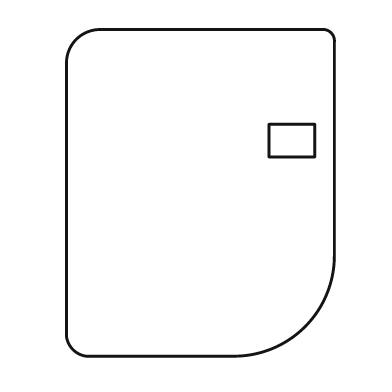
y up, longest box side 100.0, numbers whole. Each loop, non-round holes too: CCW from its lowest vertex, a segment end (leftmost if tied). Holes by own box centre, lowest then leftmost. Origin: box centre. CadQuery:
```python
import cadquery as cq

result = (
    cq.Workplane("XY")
    .moveTo(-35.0, -50.0)
    .lineTo(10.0, -50.0)
    .threePointArc((32.0, -41.0), (41.0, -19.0))
    .lineTo(41.0, 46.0)
    .threePointArc((40.0, 49.0), (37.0, 50.0))
    .lineTo(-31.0, 50.0)
    .threePointArc((-38.0, 47.0), (-41.0, 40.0))
    .lineTo(-41.0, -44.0)
    .threePointArc((-39.0, -48.0), (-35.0, -50.0))
    .close()
    .moveTo(21.0, 11.0)
    .lineTo(35.0, 11.0)
    .lineTo(35.0, 21.0)
    .lineTo(21.0, 21.0)
    .close()
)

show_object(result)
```